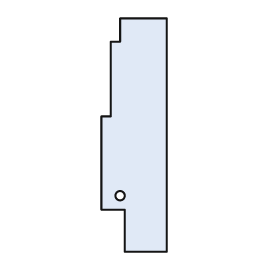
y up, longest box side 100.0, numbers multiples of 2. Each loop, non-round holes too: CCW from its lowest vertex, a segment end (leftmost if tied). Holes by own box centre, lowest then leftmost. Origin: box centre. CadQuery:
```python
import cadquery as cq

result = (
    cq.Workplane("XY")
    .moveTo(-4.0, -50.0)
    .lineTo(14.0, -50.0)
    .lineTo(14.0, 50.0)
    .lineTo(-6.0, 50.0)
    .lineTo(-6.0, 40.0)
    .lineTo(-10.0, 40.0)
    .lineTo(-10.0, 8.0)
    .lineTo(-14.0, 8.0)
    .lineTo(-14.0, -32.0)
    .lineTo(-4.0, -32.0)
    .close()
    .moveTo(-6.0, -26.0)
    .circle(2.0)
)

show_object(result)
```